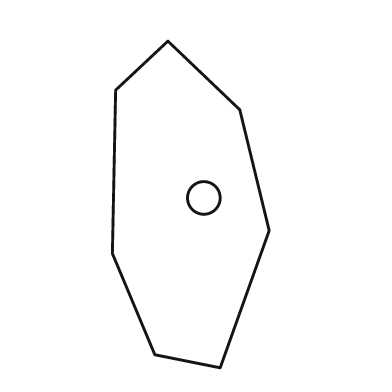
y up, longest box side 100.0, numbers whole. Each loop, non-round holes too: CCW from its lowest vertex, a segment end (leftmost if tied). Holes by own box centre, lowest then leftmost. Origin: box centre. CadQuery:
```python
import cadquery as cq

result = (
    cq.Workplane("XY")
    .moveTo(9.0, -50.0)
    .lineTo(24.0, -8.0)
    .lineTo(15.0, 29.0)
    .lineTo(-7.0, 50.0)
    .lineTo(-23.0, 35.0)
    .lineTo(-24.0, -15.0)
    .lineTo(-11.0, -46.0)
    .close()
    .moveTo(4.0, 2.0)
    .circle(5.0)
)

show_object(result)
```